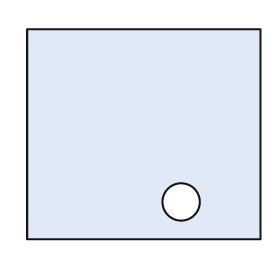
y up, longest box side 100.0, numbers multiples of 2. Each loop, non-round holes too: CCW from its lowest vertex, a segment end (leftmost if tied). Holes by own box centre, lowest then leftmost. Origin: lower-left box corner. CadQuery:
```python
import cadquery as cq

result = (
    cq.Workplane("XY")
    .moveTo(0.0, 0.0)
    .lineTo(100.0, 0.0)
    .lineTo(100.0, 90.0)
    .lineTo(0.0, 90.0)
    .close()
    .moveTo(66.0, 16.0)
    .circle(8.0)
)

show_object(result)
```